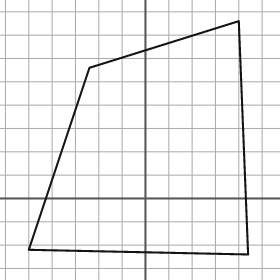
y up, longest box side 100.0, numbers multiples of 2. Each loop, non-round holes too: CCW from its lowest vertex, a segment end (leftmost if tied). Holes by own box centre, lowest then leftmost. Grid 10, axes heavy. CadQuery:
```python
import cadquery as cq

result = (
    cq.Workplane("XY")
    .moveTo(44.0, -24.0)
    .lineTo(40.0, 76.0)
    .lineTo(-24.0, 56.0)
    .lineTo(-50.0, -22.0)
    .close()
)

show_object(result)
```